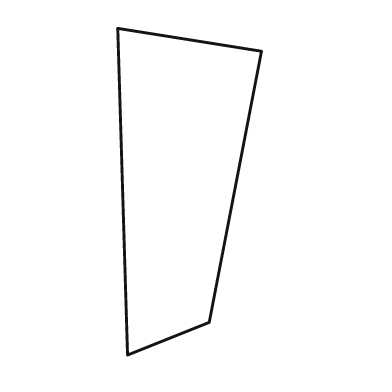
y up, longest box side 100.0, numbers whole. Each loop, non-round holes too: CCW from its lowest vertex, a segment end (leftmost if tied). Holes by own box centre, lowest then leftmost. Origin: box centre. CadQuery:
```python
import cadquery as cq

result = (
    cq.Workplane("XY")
    .moveTo(-19.0, -50.0)
    .lineTo(6.0, -40.0)
    .lineTo(22.0, 43.0)
    .lineTo(-22.0, 50.0)
    .close()
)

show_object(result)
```